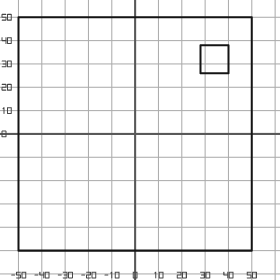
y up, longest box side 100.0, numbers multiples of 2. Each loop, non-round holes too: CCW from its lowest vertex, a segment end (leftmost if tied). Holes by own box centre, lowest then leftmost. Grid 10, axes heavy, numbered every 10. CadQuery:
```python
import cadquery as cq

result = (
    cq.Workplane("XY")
    .moveTo(-50.0, -50.0)
    .lineTo(50.0, -50.0)
    .lineTo(50.0, 50.0)
    .lineTo(-50.0, 50.0)
    .close()
    .moveTo(28.0, 26.0)
    .lineTo(40.0, 26.0)
    .lineTo(40.0, 38.0)
    .lineTo(28.0, 38.0)
    .close()
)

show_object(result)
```